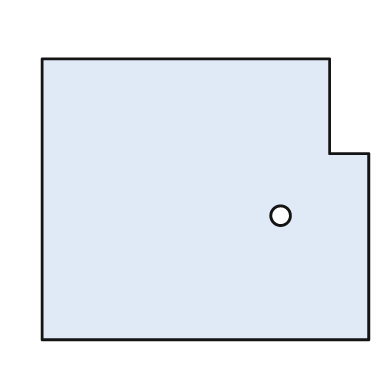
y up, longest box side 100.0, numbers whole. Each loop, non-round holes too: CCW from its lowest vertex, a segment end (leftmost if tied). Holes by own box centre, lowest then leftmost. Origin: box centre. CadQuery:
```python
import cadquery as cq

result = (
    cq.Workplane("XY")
    .moveTo(-50.0, -43.0)
    .lineTo(50.0, -43.0)
    .lineTo(50.0, 14.0)
    .lineTo(38.0, 14.0)
    .lineTo(38.0, 43.0)
    .lineTo(-50.0, 43.0)
    .close()
    .moveTo(23.0, -5.0)
    .circle(3.0)
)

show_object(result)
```